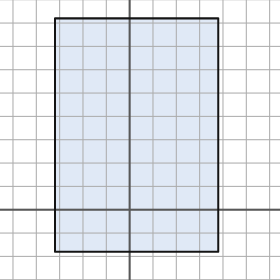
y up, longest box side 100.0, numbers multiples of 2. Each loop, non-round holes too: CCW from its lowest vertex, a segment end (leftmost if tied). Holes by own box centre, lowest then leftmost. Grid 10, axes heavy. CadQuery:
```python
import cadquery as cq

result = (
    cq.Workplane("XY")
    .moveTo(-32.0, -18.0)
    .lineTo(38.0, -18.0)
    .lineTo(38.0, 82.0)
    .lineTo(-32.0, 82.0)
    .close()
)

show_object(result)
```